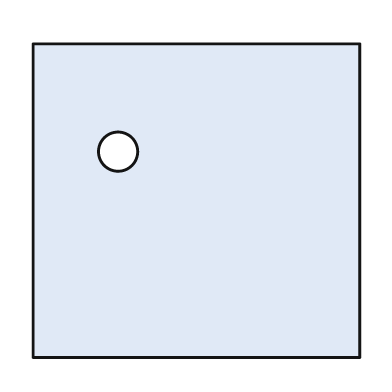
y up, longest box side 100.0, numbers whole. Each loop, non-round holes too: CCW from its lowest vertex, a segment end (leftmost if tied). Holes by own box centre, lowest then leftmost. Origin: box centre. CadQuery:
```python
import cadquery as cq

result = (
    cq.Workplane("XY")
    .moveTo(-50.0, -48.0)
    .lineTo(50.0, -48.0)
    .lineTo(50.0, 48.0)
    .lineTo(-50.0, 48.0)
    .close()
    .moveTo(-24.0, 15.0)
    .circle(6.0)
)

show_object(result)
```